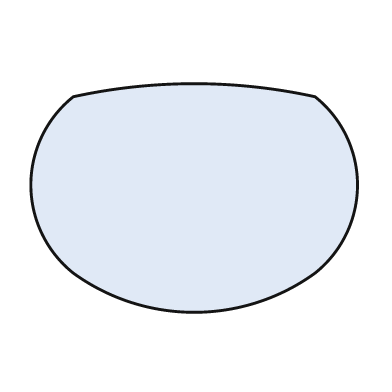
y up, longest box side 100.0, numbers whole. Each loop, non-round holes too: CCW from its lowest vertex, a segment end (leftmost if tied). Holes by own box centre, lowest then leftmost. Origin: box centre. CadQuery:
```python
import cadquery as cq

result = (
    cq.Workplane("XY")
    .moveTo(-37.0, -23.0)
    .threePointArc((0.0, -35.0), (37.0, -23.0))
    .threePointArc((50.0, 4.0), (37.0, 31.0))
    .threePointArc((0.0, 35.0), (-37.0, 31.0))
    .threePointArc((-50.0, 4.0), (-37.0, -23.0))
    .close()
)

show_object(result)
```